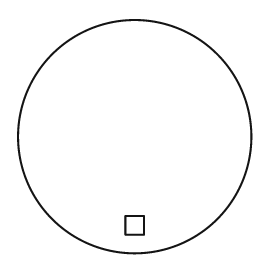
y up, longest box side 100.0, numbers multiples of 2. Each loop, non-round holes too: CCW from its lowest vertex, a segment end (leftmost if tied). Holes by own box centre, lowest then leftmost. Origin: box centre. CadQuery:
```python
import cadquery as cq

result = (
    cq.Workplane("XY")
    .moveTo(0.0, 0.0)
    .circle(50.0)
    .moveTo(-4.0, -42.0)
    .lineTo(4.0, -42.0)
    .lineTo(4.0, -34.0)
    .lineTo(-4.0, -34.0)
    .close()
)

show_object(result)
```